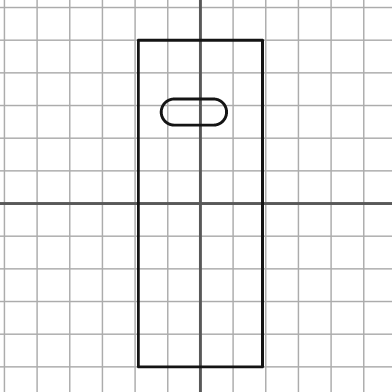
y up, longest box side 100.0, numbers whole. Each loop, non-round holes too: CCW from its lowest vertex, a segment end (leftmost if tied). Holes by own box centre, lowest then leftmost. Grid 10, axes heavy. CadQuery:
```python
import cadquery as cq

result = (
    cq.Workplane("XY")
    .moveTo(-19.0, -50.0)
    .lineTo(19.0, -50.0)
    .lineTo(19.0, 50.0)
    .lineTo(-19.0, 50.0)
    .close()
    .moveTo(-8.0, 24.0)
    .lineTo(4.0, 24.0)
    .threePointArc((8.0, 28.0), (4.0, 32.0))
    .lineTo(-8.0, 32.0)
    .threePointArc((-12.0, 28.0), (-8.0, 24.0))
    .close()
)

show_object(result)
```